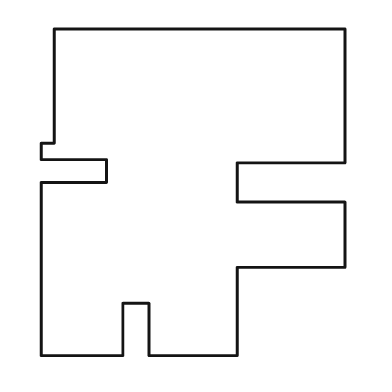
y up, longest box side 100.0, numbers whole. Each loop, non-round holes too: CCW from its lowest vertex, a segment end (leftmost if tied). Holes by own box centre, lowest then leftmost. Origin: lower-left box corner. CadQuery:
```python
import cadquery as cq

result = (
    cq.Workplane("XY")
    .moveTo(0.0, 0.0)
    .lineTo(25.0, 0.0)
    .lineTo(25.0, 16.0)
    .lineTo(33.0, 16.0)
    .lineTo(33.0, 0.0)
    .lineTo(60.0, 0.0)
    .lineTo(60.0, 27.0)
    .lineTo(93.0, 27.0)
    .lineTo(93.0, 47.0)
    .lineTo(60.0, 47.0)
    .lineTo(60.0, 59.0)
    .lineTo(93.0, 59.0)
    .lineTo(93.0, 100.0)
    .lineTo(4.0, 100.0)
    .lineTo(4.0, 65.0)
    .lineTo(0.0, 65.0)
    .lineTo(0.0, 60.0)
    .lineTo(20.0, 60.0)
    .lineTo(20.0, 53.0)
    .lineTo(0.0, 53.0)
    .close()
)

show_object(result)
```